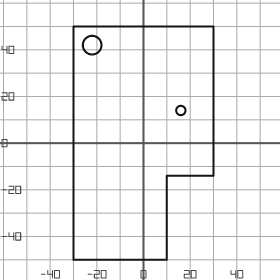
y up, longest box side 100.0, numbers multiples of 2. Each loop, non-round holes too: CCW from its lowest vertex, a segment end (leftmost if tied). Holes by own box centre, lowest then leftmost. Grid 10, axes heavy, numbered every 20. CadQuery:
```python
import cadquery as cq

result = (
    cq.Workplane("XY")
    .moveTo(-30.0, -50.0)
    .lineTo(10.0, -50.0)
    .lineTo(10.0, -14.0)
    .lineTo(30.0, -14.0)
    .lineTo(30.0, 50.0)
    .lineTo(-30.0, 50.0)
    .close()
    .moveTo(16.0, 14.0)
    .circle(2.0)
    .moveTo(-22.0, 42.0)
    .circle(4.0)
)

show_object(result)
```